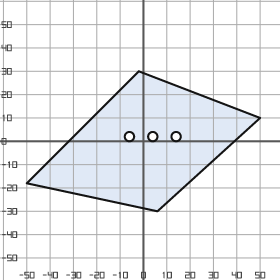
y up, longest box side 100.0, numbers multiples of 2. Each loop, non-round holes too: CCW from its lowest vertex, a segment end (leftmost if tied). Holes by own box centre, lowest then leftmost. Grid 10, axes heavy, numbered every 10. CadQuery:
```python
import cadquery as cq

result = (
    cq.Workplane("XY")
    .moveTo(6.0, -30.0)
    .lineTo(50.0, 10.0)
    .lineTo(-2.0, 30.0)
    .lineTo(-50.0, -18.0)
    .close()
    .moveTo(-6.0, 2.0)
    .circle(2.0)
    .moveTo(4.0, 2.0)
    .circle(2.0)
    .moveTo(14.0, 2.0)
    .circle(2.0)
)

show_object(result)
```